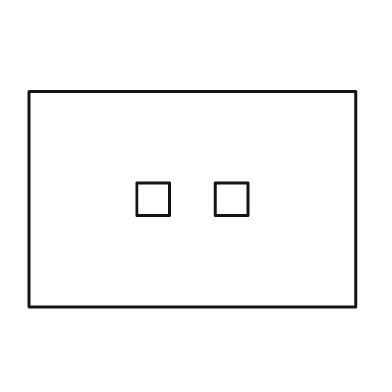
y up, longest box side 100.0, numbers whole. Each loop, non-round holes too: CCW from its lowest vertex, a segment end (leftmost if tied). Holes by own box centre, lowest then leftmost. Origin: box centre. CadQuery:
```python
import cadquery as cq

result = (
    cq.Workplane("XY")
    .moveTo(-50.0, -33.0)
    .lineTo(50.0, -33.0)
    .lineTo(50.0, 33.0)
    .lineTo(-50.0, 33.0)
    .close()
    .moveTo(-17.0, -5.0)
    .lineTo(-7.0, -5.0)
    .lineTo(-7.0, 5.0)
    .lineTo(-17.0, 5.0)
    .close()
    .moveTo(7.0, -5.0)
    .lineTo(17.0, -5.0)
    .lineTo(17.0, 5.0)
    .lineTo(7.0, 5.0)
    .close()
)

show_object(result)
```